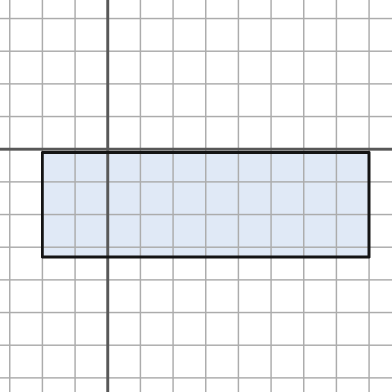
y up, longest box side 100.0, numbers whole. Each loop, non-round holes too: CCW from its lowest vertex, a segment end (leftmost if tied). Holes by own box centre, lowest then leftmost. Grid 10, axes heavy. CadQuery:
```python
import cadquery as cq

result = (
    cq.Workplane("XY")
    .moveTo(-20.0, -33.0)
    .lineTo(80.0, -33.0)
    .lineTo(80.0, -1.0)
    .lineTo(-20.0, -1.0)
    .close()
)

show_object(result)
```